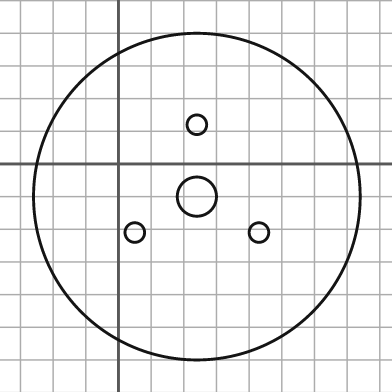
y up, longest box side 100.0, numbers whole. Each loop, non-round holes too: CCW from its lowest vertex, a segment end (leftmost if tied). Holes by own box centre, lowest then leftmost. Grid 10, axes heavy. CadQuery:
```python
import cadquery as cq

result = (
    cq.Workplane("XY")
    .moveTo(24.0, -10.0)
    .circle(50.0)
    .moveTo(5.0, -21.0)
    .circle(3.0)
    .moveTo(43.0, -21.0)
    .circle(3.0)
    .moveTo(24.0, -10.0)
    .circle(6.0)
    .moveTo(24.0, 12.0)
    .circle(3.0)
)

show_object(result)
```